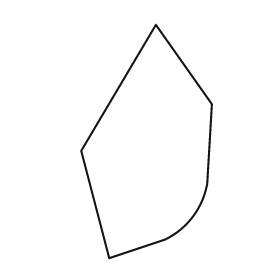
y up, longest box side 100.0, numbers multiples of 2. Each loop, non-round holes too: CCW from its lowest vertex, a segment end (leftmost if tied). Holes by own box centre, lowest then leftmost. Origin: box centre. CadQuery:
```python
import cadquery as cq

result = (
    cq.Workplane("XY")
    .moveTo(-16.0, -50.0)
    .lineTo(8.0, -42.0)
    .threePointArc((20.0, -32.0), (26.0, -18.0))
    .lineTo(28.0, 16.0)
    .lineTo(4.0, 50.0)
    .lineTo(-28.0, -4.0)
    .close()
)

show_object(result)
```